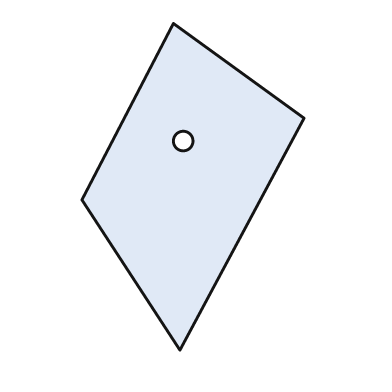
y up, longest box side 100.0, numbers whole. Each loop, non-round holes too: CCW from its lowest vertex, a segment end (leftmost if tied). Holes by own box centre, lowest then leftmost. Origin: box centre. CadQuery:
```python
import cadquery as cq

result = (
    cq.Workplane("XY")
    .moveTo(-4.0, -50.0)
    .lineTo(34.0, 21.0)
    .lineTo(-6.0, 50.0)
    .lineTo(-34.0, -4.0)
    .close()
    .moveTo(-3.0, 14.0)
    .circle(3.0)
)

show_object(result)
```